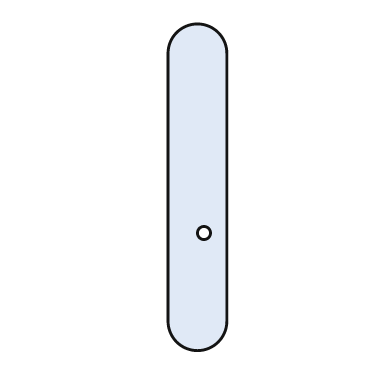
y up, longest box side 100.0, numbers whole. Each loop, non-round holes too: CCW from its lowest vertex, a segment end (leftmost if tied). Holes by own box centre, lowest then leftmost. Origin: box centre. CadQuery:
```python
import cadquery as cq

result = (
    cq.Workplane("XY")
    .moveTo(-9.0, -41.0)
    .threePointArc((0.0, -50.0), (9.0, -41.0))
    .lineTo(9.0, 41.0)
    .threePointArc((0.0, 50.0), (-9.0, 41.0))
    .close()
    .moveTo(2.0, -14.0)
    .circle(2.0)
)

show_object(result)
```